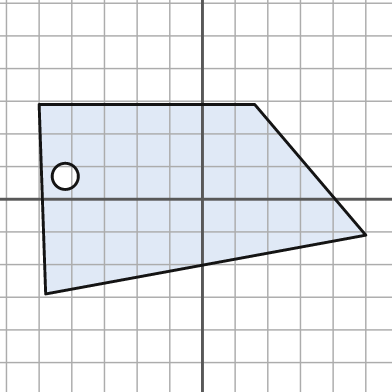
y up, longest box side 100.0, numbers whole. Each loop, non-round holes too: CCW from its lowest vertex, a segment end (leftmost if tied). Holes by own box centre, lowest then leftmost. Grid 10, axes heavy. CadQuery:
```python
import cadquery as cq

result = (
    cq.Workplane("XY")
    .moveTo(-48.0, -29.0)
    .lineTo(50.0, -11.0)
    .lineTo(16.0, 29.0)
    .lineTo(-50.0, 29.0)
    .close()
    .moveTo(-42.0, 7.0)
    .circle(4.0)
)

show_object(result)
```